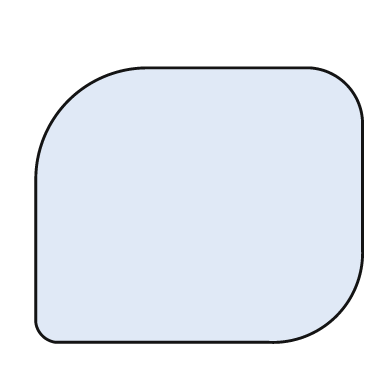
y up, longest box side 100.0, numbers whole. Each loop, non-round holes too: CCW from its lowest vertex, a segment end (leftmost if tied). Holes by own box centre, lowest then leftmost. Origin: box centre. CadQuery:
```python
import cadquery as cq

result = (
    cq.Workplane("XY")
    .moveTo(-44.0, -42.0)
    .lineTo(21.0, -42.0)
    .threePointArc((42.0, -34.0), (50.0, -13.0))
    .lineTo(50.0, 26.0)
    .threePointArc((45.0, 37.0), (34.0, 42.0))
    .lineTo(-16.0, 42.0)
    .threePointArc((-40.0, 32.0), (-50.0, 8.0))
    .lineTo(-50.0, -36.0)
    .threePointArc((-48.0, -40.0), (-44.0, -42.0))
    .close()
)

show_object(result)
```